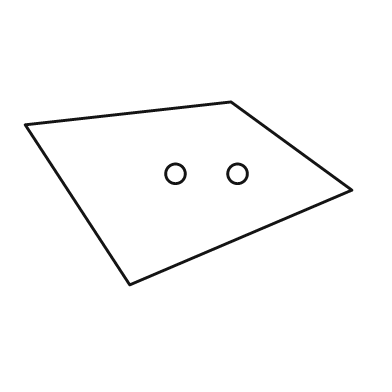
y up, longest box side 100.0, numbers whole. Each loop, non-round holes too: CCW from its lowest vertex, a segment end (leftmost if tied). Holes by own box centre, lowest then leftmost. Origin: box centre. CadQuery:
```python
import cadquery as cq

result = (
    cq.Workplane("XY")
    .moveTo(-18.0, -28.0)
    .lineTo(50.0, 1.0)
    .lineTo(13.0, 28.0)
    .lineTo(-50.0, 21.0)
    .close()
    .moveTo(-4.0, 6.0)
    .circle(3.0)
    .moveTo(15.0, 6.0)
    .circle(3.0)
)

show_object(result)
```